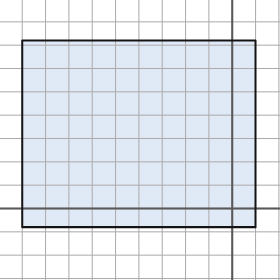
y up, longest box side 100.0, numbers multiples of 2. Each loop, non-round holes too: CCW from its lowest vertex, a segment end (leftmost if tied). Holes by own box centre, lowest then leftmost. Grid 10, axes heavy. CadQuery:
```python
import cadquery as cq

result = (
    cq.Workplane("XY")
    .moveTo(-90.0, -8.0)
    .lineTo(10.0, -8.0)
    .lineTo(10.0, 72.0)
    .lineTo(-90.0, 72.0)
    .close()
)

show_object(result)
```